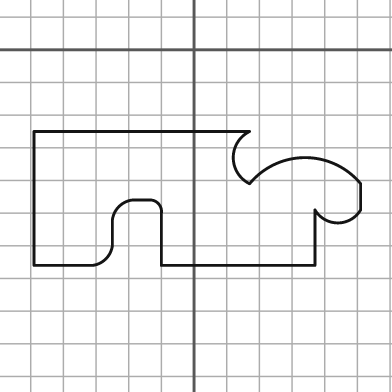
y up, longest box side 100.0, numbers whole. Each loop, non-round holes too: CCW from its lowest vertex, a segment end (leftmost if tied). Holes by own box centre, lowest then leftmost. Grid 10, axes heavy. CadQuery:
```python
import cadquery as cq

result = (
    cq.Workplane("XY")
    .moveTo(-49.0, -66.0)
    .lineTo(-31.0, -66.0)
    .threePointArc((-27.0, -64.0), (-25.0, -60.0))
    .lineTo(-25.0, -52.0)
    .threePointArc((-23.0, -48.0), (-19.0, -46.0))
    .lineTo(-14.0, -46.0)
    .threePointArc((-11.0, -47.0), (-10.0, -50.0))
    .lineTo(-10.0, -66.0)
    .lineTo(37.0, -66.0)
    .lineTo(37.0, -49.0)
    .threePointArc((44.0, -53.0), (51.0, -49.0))
    .lineTo(51.0, -41.0)
    .threePointArc((34.0, -33.0), (17.0, -41.0))
    .threePointArc((12.0, -33.0), (17.0, -25.0))
    .lineTo(-49.0, -25.0)
    .close()
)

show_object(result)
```